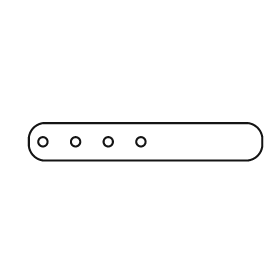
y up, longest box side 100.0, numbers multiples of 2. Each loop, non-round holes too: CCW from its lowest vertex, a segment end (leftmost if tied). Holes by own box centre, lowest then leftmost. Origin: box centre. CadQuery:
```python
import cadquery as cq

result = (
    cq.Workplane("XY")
    .moveTo(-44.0, -8.0)
    .lineTo(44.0, -8.0)
    .threePointArc((48.0, -6.0), (50.0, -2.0))
    .lineTo(50.0, 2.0)
    .threePointArc((48.0, 6.0), (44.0, 8.0))
    .lineTo(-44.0, 8.0)
    .threePointArc((-48.0, 6.0), (-50.0, 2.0))
    .lineTo(-50.0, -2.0)
    .threePointArc((-48.0, -6.0), (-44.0, -8.0))
    .close()
    .moveTo(-44.0, 0.0)
    .circle(2.0)
    .moveTo(-30.0, 0.0)
    .circle(2.0)
    .moveTo(-16.0, 0.0)
    .circle(2.0)
    .moveTo(-2.0, 0.0)
    .circle(2.0)
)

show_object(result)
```